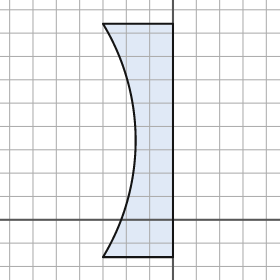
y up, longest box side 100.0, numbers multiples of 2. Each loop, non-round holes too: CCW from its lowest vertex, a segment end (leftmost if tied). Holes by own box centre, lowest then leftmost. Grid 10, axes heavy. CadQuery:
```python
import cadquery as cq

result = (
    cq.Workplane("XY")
    .moveTo(-30.0, -16.0)
    .lineTo(0.0, -16.0)
    .lineTo(0.0, 84.0)
    .lineTo(-30.0, 84.0)
    .threePointArc((-16.0, 34.0), (-30.0, -16.0))
    .close()
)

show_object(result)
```